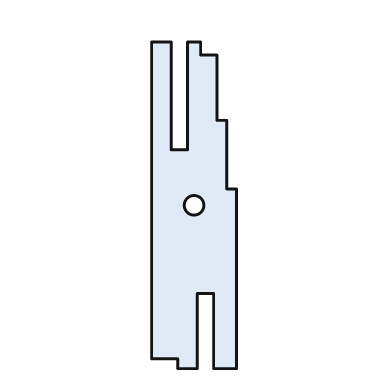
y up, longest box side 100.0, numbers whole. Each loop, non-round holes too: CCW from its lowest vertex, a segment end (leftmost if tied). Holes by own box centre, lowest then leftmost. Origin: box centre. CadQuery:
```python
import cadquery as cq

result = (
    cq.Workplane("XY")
    .moveTo(-5.0, -50.0)
    .lineTo(1.0, -50.0)
    .lineTo(1.0, -27.0)
    .lineTo(6.0, -27.0)
    .lineTo(6.0, -50.0)
    .lineTo(13.0, -50.0)
    .lineTo(13.0, 5.0)
    .lineTo(10.0, 5.0)
    .lineTo(10.0, 26.0)
    .lineTo(7.0, 26.0)
    .lineTo(7.0, 46.0)
    .lineTo(2.0, 46.0)
    .lineTo(2.0, 50.0)
    .lineTo(-2.0, 50.0)
    .lineTo(-2.0, 17.0)
    .lineTo(-7.0, 17.0)
    .lineTo(-7.0, 50.0)
    .lineTo(-13.0, 50.0)
    .lineTo(-13.0, -47.0)
    .lineTo(-5.0, -47.0)
    .close()
    .moveTo(0.0, 0.0)
    .circle(3.0)
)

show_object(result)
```